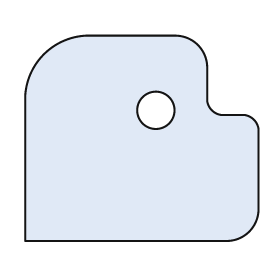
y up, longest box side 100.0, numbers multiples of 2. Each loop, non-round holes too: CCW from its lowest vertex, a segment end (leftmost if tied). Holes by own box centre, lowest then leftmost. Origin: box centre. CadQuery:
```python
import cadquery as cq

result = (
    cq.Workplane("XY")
    .moveTo(-50.0, -44.0)
    .lineTo(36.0, -44.0)
    .threePointArc((46.0, -40.0), (50.0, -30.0))
    .lineTo(50.0, 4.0)
    .threePointArc((48.0, 8.0), (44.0, 10.0))
    .lineTo(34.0, 10.0)
    .threePointArc((30.0, 12.0), (28.0, 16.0))
    .lineTo(28.0, 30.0)
    .threePointArc((24.0, 40.0), (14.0, 44.0))
    .lineTo(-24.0, 44.0)
    .threePointArc((-42.0, 36.0), (-50.0, 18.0))
    .close()
    .moveTo(6.0, 12.0)
    .circle(8.0)
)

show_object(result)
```